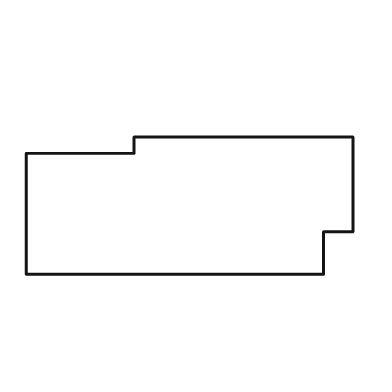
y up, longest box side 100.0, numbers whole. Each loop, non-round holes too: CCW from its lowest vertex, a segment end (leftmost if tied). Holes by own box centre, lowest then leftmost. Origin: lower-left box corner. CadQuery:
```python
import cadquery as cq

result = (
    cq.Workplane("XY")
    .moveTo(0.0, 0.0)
    .lineTo(91.0, 0.0)
    .lineTo(91.0, 13.0)
    .lineTo(100.0, 13.0)
    .lineTo(100.0, 42.0)
    .lineTo(33.0, 42.0)
    .lineTo(33.0, 37.0)
    .lineTo(0.0, 37.0)
    .close()
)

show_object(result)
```